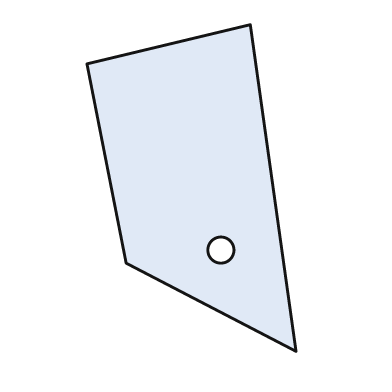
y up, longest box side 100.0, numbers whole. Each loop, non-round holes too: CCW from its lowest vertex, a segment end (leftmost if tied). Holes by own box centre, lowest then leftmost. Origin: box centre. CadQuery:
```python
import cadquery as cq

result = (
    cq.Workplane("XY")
    .moveTo(32.0, -50.0)
    .lineTo(18.0, 50.0)
    .lineTo(-32.0, 38.0)
    .lineTo(-20.0, -23.0)
    .close()
    .moveTo(9.0, -19.0)
    .circle(4.0)
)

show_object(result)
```